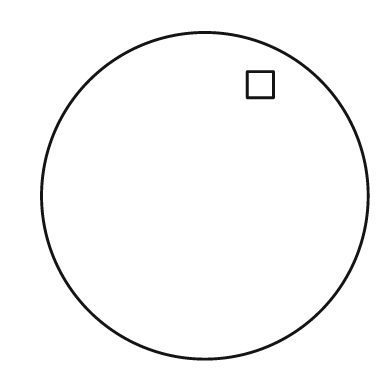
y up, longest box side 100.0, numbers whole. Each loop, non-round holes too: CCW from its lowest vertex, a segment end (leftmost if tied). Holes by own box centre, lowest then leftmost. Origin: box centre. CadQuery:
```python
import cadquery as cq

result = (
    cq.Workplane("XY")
    .moveTo(0.0, 0.0)
    .circle(50.0)
    .moveTo(13.0, 30.0)
    .lineTo(21.0, 30.0)
    .lineTo(21.0, 38.0)
    .lineTo(13.0, 38.0)
    .close()
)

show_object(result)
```